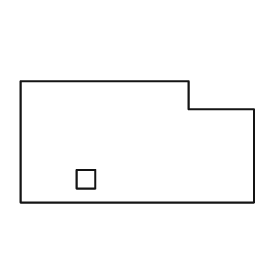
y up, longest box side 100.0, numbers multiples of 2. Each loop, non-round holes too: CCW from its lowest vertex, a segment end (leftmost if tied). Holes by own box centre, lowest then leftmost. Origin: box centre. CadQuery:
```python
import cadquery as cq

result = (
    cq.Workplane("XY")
    .moveTo(-50.0, -26.0)
    .lineTo(50.0, -26.0)
    .lineTo(50.0, 14.0)
    .lineTo(22.0, 14.0)
    .lineTo(22.0, 26.0)
    .lineTo(-50.0, 26.0)
    .close()
    .moveTo(-26.0, -20.0)
    .lineTo(-18.0, -20.0)
    .lineTo(-18.0, -12.0)
    .lineTo(-26.0, -12.0)
    .close()
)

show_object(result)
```